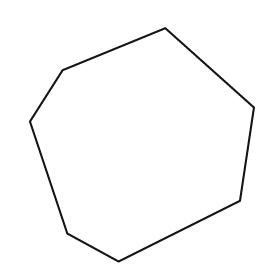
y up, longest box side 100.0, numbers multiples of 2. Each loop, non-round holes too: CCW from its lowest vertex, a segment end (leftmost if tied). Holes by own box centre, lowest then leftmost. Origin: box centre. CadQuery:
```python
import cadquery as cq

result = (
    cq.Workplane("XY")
    .moveTo(-10.0, -50.0)
    .lineTo(42.0, -24.0)
    .lineTo(48.0, 16.0)
    .lineTo(10.0, 50.0)
    .lineTo(-34.0, 32.0)
    .lineTo(-48.0, 10.0)
    .lineTo(-32.0, -38.0)
    .close()
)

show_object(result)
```